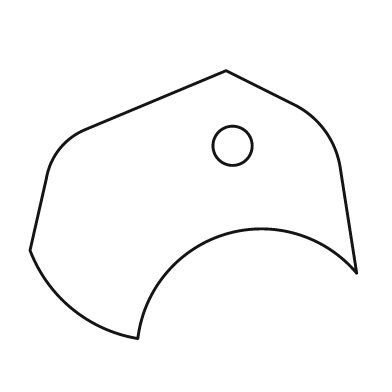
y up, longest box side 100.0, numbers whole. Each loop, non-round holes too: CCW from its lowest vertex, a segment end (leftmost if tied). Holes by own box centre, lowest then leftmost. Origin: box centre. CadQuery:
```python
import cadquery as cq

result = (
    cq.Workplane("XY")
    .moveTo(-17.0, -41.0)
    .threePointArc((10.0, -9.0), (50.0, -21.0))
    .lineTo(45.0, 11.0)
    .threePointArc((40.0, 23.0), (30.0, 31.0))
    .lineTo(10.0, 41.0)
    .lineTo(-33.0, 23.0)
    .threePointArc((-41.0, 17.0), (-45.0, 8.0))
    .lineTo(-50.0, -14.0)
    .threePointArc((-37.0, -32.0), (-17.0, -41.0))
    .close()
    .moveTo(12.0, 18.0)
    .circle(6.0)
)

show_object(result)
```